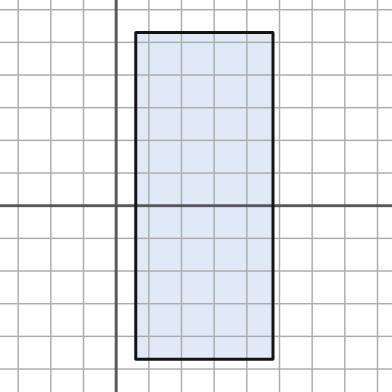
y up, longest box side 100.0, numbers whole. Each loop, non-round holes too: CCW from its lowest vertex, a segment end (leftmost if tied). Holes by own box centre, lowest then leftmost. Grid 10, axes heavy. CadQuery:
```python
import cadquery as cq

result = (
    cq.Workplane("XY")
    .moveTo(6.0, -47.0)
    .lineTo(48.0, -47.0)
    .lineTo(48.0, 53.0)
    .lineTo(6.0, 53.0)
    .close()
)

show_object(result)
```